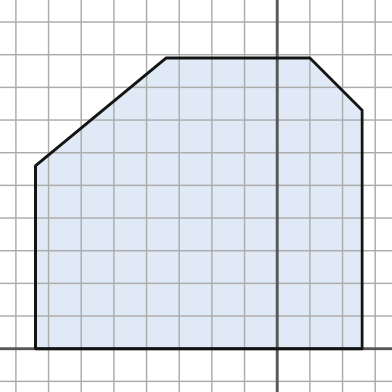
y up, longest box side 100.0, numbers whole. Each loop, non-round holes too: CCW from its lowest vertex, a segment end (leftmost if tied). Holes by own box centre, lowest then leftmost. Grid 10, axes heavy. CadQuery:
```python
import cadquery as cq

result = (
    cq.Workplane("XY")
    .moveTo(-74.0, 0.0)
    .lineTo(26.0, 0.0)
    .lineTo(26.0, 73.0)
    .lineTo(10.0, 89.0)
    .lineTo(-34.0, 89.0)
    .lineTo(-74.0, 56.0)
    .close()
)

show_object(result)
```